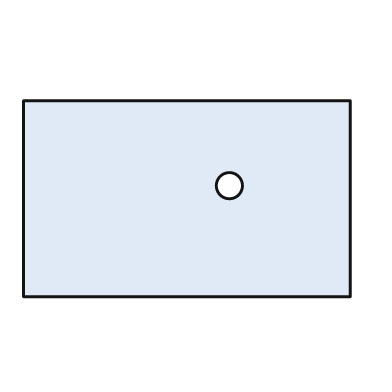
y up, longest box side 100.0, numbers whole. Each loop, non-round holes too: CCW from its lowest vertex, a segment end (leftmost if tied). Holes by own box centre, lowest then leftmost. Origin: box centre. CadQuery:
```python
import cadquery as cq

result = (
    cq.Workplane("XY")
    .moveTo(-50.0, -30.0)
    .lineTo(50.0, -30.0)
    .lineTo(50.0, 30.0)
    .lineTo(-50.0, 30.0)
    .close()
    .moveTo(13.0, 4.0)
    .circle(4.0)
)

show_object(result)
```